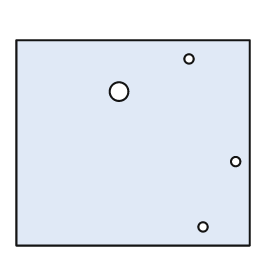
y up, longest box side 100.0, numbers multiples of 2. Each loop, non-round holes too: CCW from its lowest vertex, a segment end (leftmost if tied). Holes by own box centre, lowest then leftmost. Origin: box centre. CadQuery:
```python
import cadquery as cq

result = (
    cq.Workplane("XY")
    .moveTo(-50.0, -44.0)
    .lineTo(50.0, -44.0)
    .lineTo(50.0, 44.0)
    .lineTo(-50.0, 44.0)
    .close()
    .moveTo(30.0, -36.0)
    .circle(2.0)
    .moveTo(44.0, -8.0)
    .circle(2.0)
    .moveTo(-6.0, 22.0)
    .circle(4.0)
    .moveTo(24.0, 36.0)
    .circle(2.0)
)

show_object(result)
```